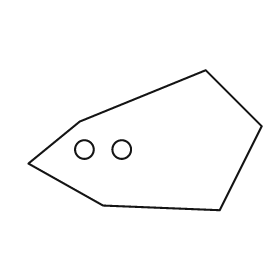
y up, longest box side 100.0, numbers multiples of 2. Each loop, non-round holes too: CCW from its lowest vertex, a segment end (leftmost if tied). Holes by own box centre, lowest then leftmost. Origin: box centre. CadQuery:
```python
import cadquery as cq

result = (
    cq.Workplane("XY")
    .moveTo(32.0, -30.0)
    .lineTo(50.0, 6.0)
    .lineTo(26.0, 30.0)
    .lineTo(-28.0, 8.0)
    .lineTo(-50.0, -10.0)
    .lineTo(-18.0, -28.0)
    .close()
    .moveTo(-26.0, -4.0)
    .circle(4.0)
    .moveTo(-10.0, -4.0)
    .circle(4.0)
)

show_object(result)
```